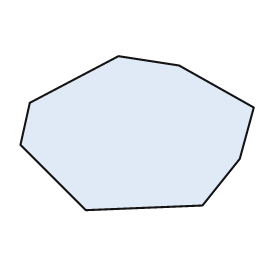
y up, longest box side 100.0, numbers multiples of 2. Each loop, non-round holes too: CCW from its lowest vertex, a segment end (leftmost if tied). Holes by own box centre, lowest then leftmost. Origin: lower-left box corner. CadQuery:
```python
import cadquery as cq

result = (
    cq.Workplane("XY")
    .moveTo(28.0, 0.0)
    .lineTo(78.0, 2.0)
    .lineTo(94.0, 22.0)
    .lineTo(100.0, 44.0)
    .lineTo(68.0, 62.0)
    .lineTo(42.0, 66.0)
    .lineTo(4.0, 46.0)
    .lineTo(0.0, 28.0)
    .close()
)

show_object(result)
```